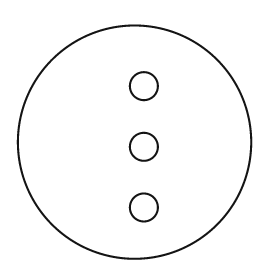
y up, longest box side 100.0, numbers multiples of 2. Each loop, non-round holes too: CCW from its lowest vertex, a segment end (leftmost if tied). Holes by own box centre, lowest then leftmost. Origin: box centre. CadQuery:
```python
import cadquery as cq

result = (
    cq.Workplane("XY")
    .moveTo(0.0, 0.0)
    .circle(50.0)
    .moveTo(4.0, -28.0)
    .circle(6.0)
    .moveTo(4.0, -2.0)
    .circle(6.0)
    .moveTo(4.0, 24.0)
    .circle(6.0)
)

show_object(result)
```